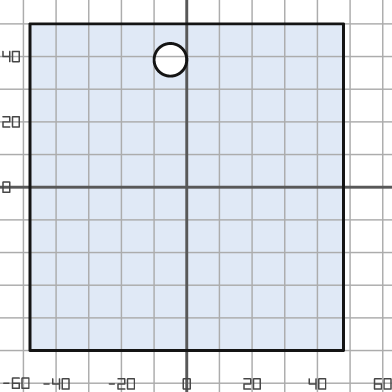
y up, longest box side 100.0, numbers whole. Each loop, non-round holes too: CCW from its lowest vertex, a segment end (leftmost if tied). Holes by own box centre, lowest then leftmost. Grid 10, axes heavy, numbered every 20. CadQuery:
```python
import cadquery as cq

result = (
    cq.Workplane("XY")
    .moveTo(-48.0, -50.0)
    .lineTo(48.0, -50.0)
    .lineTo(48.0, 50.0)
    .lineTo(-48.0, 50.0)
    .close()
    .moveTo(-5.0, 39.0)
    .circle(5.0)
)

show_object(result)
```